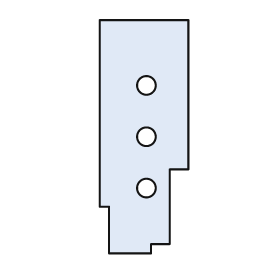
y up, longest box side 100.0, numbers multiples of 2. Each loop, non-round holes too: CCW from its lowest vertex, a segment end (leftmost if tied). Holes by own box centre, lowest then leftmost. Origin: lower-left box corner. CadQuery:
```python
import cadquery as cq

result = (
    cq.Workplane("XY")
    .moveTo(4.0, 0.0)
    .lineTo(22.0, 0.0)
    .lineTo(22.0, 4.0)
    .lineTo(30.0, 4.0)
    .lineTo(30.0, 36.0)
    .lineTo(38.0, 36.0)
    .lineTo(38.0, 100.0)
    .lineTo(0.0, 100.0)
    .lineTo(0.0, 20.0)
    .lineTo(4.0, 20.0)
    .close()
    .moveTo(20.0, 28.0)
    .circle(4.0)
    .moveTo(20.0, 50.0)
    .circle(4.0)
    .moveTo(20.0, 72.0)
    .circle(4.0)
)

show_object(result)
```